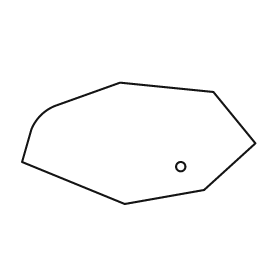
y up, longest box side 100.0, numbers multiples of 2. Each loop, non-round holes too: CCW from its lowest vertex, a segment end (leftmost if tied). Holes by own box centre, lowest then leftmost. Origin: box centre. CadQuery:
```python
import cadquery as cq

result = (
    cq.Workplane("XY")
    .moveTo(-6.0, -26.0)
    .lineTo(28.0, -20.0)
    .lineTo(50.0, 0.0)
    .lineTo(32.0, 22.0)
    .lineTo(-8.0, 26.0)
    .lineTo(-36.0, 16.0)
    .threePointArc((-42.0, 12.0), (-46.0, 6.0))
    .lineTo(-50.0, -8.0)
    .close()
    .moveTo(18.0, -10.0)
    .circle(2.0)
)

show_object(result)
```